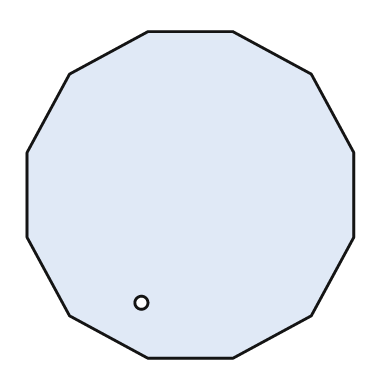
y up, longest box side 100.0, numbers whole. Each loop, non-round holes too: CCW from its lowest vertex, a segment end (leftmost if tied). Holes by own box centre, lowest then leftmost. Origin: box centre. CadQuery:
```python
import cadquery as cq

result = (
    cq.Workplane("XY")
    .moveTo(-13.0, -50.0)
    .lineTo(13.0, -50.0)
    .lineTo(37.0, -37.0)
    .lineTo(50.0, -13.0)
    .lineTo(50.0, 13.0)
    .lineTo(37.0, 37.0)
    .lineTo(13.0, 50.0)
    .lineTo(-13.0, 50.0)
    .lineTo(-37.0, 37.0)
    .lineTo(-50.0, 13.0)
    .lineTo(-50.0, -13.0)
    .lineTo(-37.0, -37.0)
    .close()
    .moveTo(-15.0, -33.0)
    .circle(2.0)
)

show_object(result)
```